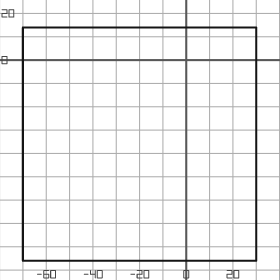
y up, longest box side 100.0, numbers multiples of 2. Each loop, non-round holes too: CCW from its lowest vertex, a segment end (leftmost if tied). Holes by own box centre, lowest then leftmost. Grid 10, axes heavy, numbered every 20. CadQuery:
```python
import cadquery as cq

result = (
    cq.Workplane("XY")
    .moveTo(-70.0, -86.0)
    .lineTo(30.0, -86.0)
    .lineTo(30.0, 14.0)
    .lineTo(-70.0, 14.0)
    .close()
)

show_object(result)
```